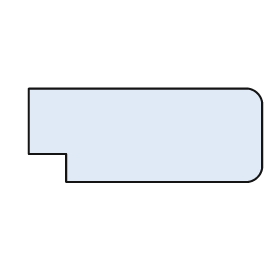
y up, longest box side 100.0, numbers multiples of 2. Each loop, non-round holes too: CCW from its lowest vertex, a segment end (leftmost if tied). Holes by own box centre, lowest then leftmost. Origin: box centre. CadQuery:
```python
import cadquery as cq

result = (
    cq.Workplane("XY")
    .moveTo(-34.0, -20.0)
    .lineTo(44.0, -20.0)
    .threePointArc((48.0, -18.0), (50.0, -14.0))
    .lineTo(50.0, 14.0)
    .threePointArc((48.0, 18.0), (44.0, 20.0))
    .lineTo(-50.0, 20.0)
    .lineTo(-50.0, -8.0)
    .lineTo(-34.0, -8.0)
    .close()
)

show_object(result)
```